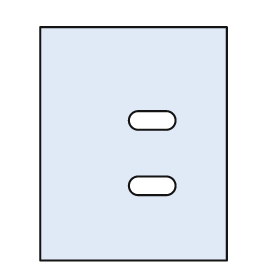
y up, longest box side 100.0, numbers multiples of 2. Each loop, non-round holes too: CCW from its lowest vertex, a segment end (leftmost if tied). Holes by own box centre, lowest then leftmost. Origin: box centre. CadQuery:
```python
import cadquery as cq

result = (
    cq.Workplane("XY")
    .moveTo(-40.0, -50.0)
    .lineTo(40.0, -50.0)
    .lineTo(40.0, 50.0)
    .lineTo(-40.0, 50.0)
    .close()
    .moveTo(2.0, -22.0)
    .lineTo(14.0, -22.0)
    .threePointArc((18.0, -18.0), (14.0, -14.0))
    .lineTo(2.0, -14.0)
    .threePointArc((-2.0, -18.0), (2.0, -22.0))
    .close()
    .moveTo(2.0, 6.0)
    .lineTo(14.0, 6.0)
    .threePointArc((18.0, 10.0), (14.0, 14.0))
    .lineTo(2.0, 14.0)
    .threePointArc((-2.0, 10.0), (2.0, 6.0))
    .close()
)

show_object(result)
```